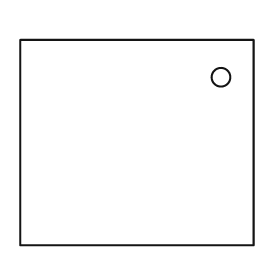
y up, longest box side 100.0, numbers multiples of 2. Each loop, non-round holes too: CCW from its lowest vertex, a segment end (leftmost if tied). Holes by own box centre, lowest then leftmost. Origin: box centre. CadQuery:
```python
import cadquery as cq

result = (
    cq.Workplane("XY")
    .moveTo(-50.0, -44.0)
    .lineTo(50.0, -44.0)
    .lineTo(50.0, 44.0)
    .lineTo(-50.0, 44.0)
    .close()
    .moveTo(36.0, 28.0)
    .circle(4.0)
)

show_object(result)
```